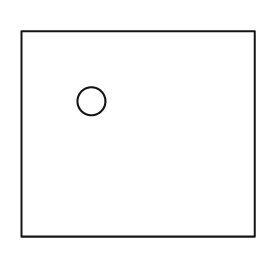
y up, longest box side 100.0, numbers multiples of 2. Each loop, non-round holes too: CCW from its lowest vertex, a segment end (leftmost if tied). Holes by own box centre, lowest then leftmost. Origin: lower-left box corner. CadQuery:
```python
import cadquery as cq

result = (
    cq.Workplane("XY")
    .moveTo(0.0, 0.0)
    .lineTo(100.0, 0.0)
    .lineTo(100.0, 88.0)
    .lineTo(0.0, 88.0)
    .close()
    .moveTo(30.0, 58.0)
    .circle(6.0)
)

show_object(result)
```